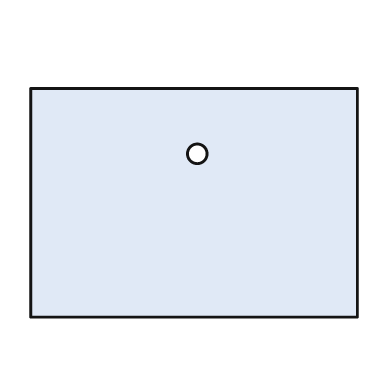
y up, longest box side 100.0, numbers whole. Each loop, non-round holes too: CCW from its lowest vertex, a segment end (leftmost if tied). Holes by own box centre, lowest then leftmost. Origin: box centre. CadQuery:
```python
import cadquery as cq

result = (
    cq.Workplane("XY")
    .moveTo(-50.0, -35.0)
    .lineTo(50.0, -35.0)
    .lineTo(50.0, 35.0)
    .lineTo(-50.0, 35.0)
    .close()
    .moveTo(1.0, 15.0)
    .circle(3.0)
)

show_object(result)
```